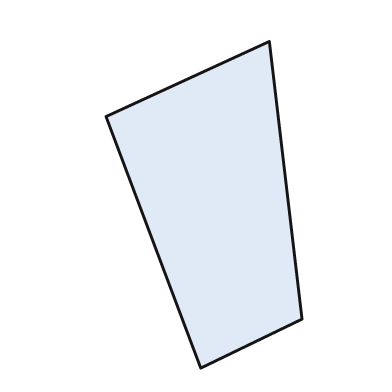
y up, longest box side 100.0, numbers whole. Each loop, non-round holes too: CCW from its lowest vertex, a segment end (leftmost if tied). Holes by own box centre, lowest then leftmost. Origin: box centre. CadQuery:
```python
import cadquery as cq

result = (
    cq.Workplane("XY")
    .moveTo(-1.0, -50.0)
    .lineTo(30.0, -35.0)
    .lineTo(20.0, 50.0)
    .lineTo(-30.0, 27.0)
    .close()
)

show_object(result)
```